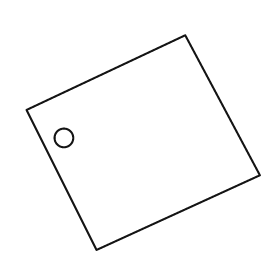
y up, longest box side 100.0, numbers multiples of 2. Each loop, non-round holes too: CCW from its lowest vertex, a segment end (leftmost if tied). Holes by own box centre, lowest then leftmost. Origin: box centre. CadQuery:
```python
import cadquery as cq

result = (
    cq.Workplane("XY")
    .moveTo(-20.0, -46.0)
    .lineTo(50.0, -14.0)
    .lineTo(18.0, 46.0)
    .lineTo(-50.0, 14.0)
    .close()
    .moveTo(-34.0, 2.0)
    .circle(4.0)
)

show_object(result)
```